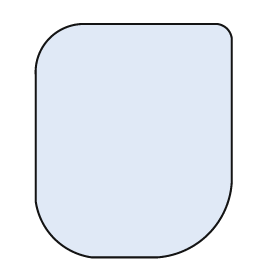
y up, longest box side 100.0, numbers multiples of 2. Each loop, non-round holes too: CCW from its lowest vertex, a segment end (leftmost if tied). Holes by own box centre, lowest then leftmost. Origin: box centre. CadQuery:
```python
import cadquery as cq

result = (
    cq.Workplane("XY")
    .moveTo(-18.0, -50.0)
    .lineTo(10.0, -50.0)
    .threePointArc((32.0, -40.0), (42.0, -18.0))
    .lineTo(42.0, 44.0)
    .threePointArc((40.0, 48.0), (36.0, 50.0))
    .lineTo(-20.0, 50.0)
    .threePointArc((-36.0, 44.0), (-42.0, 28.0))
    .lineTo(-42.0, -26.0)
    .threePointArc((-34.0, -42.0), (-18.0, -50.0))
    .close()
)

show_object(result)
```